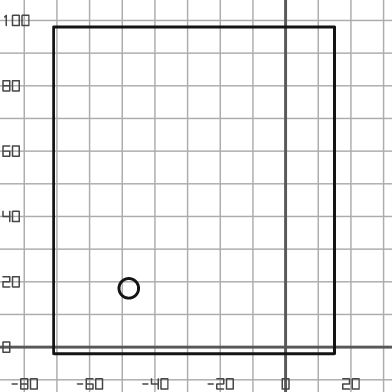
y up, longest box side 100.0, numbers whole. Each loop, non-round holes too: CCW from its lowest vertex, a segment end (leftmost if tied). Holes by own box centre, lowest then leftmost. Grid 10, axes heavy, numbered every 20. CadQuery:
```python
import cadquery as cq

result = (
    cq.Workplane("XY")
    .moveTo(-71.0, -2.0)
    .lineTo(15.0, -2.0)
    .lineTo(15.0, 98.0)
    .lineTo(-71.0, 98.0)
    .close()
    .moveTo(-48.0, 18.0)
    .circle(3.0)
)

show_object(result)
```